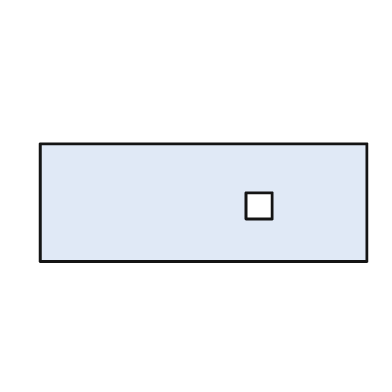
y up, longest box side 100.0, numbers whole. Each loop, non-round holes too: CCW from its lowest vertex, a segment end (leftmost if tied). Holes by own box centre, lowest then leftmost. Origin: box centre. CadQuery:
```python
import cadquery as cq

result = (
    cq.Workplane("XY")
    .moveTo(-50.0, -18.0)
    .lineTo(50.0, -18.0)
    .lineTo(50.0, 18.0)
    .lineTo(-50.0, 18.0)
    .close()
    .moveTo(13.0, -5.0)
    .lineTo(21.0, -5.0)
    .lineTo(21.0, 3.0)
    .lineTo(13.0, 3.0)
    .close()
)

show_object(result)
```